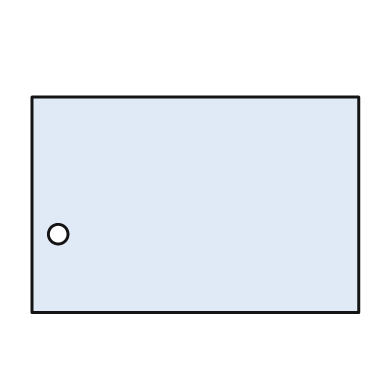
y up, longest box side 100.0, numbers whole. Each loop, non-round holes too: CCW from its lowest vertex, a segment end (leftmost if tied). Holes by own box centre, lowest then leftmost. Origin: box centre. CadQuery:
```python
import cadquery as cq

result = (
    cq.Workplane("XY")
    .moveTo(-50.0, -33.0)
    .lineTo(50.0, -33.0)
    .lineTo(50.0, 33.0)
    .lineTo(-50.0, 33.0)
    .close()
    .moveTo(-42.0, -9.0)
    .circle(3.0)
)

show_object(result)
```